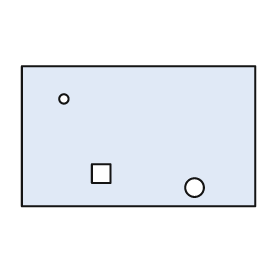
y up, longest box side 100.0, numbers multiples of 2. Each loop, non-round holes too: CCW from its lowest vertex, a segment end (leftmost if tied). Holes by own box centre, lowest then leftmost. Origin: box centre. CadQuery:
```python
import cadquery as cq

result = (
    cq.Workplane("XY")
    .moveTo(-50.0, -30.0)
    .lineTo(50.0, -30.0)
    .lineTo(50.0, 30.0)
    .lineTo(-50.0, 30.0)
    .close()
    .moveTo(24.0, -22.0)
    .circle(4.0)
    .moveTo(-20.0, -20.0)
    .lineTo(-12.0, -20.0)
    .lineTo(-12.0, -12.0)
    .lineTo(-20.0, -12.0)
    .close()
    .moveTo(-32.0, 16.0)
    .circle(2.0)
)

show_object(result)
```